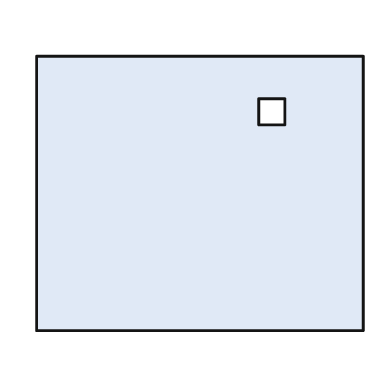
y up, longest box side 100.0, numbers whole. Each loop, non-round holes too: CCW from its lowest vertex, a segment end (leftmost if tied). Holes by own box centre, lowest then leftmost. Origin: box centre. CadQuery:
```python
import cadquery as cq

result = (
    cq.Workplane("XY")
    .moveTo(-50.0, -42.0)
    .lineTo(50.0, -42.0)
    .lineTo(50.0, 42.0)
    .lineTo(-50.0, 42.0)
    .close()
    .moveTo(18.0, 21.0)
    .lineTo(26.0, 21.0)
    .lineTo(26.0, 29.0)
    .lineTo(18.0, 29.0)
    .close()
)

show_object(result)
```